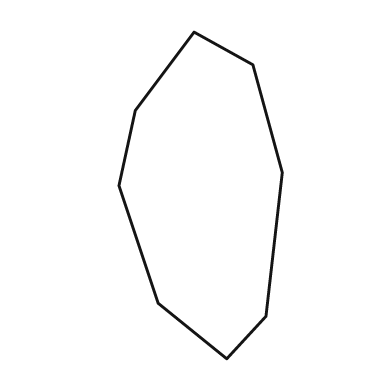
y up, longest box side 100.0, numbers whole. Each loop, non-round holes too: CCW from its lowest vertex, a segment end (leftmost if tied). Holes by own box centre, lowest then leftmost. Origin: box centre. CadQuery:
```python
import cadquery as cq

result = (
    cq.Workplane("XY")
    .moveTo(8.0, -50.0)
    .lineTo(20.0, -37.0)
    .lineTo(25.0, 7.0)
    .lineTo(16.0, 40.0)
    .lineTo(-2.0, 50.0)
    .lineTo(-20.0, 26.0)
    .lineTo(-25.0, 3.0)
    .lineTo(-13.0, -33.0)
    .close()
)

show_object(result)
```